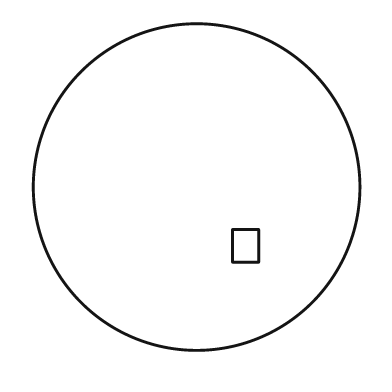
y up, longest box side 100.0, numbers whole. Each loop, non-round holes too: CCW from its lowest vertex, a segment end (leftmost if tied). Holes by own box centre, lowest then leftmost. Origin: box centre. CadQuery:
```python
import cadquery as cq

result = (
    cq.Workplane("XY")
    .moveTo(0.0, 0.0)
    .circle(50.0)
    .moveTo(11.0, -23.0)
    .lineTo(19.0, -23.0)
    .lineTo(19.0, -13.0)
    .lineTo(11.0, -13.0)
    .close()
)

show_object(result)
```